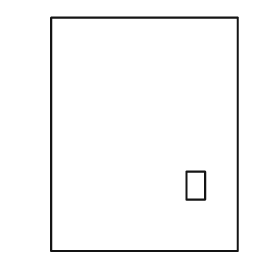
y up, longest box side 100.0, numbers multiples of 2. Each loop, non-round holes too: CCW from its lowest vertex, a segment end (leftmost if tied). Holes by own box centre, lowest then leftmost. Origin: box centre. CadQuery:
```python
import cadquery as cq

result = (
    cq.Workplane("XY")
    .moveTo(-40.0, -50.0)
    .lineTo(40.0, -50.0)
    .lineTo(40.0, 50.0)
    .lineTo(-40.0, 50.0)
    .close()
    .moveTo(18.0, -28.0)
    .lineTo(26.0, -28.0)
    .lineTo(26.0, -16.0)
    .lineTo(18.0, -16.0)
    .close()
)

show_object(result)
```